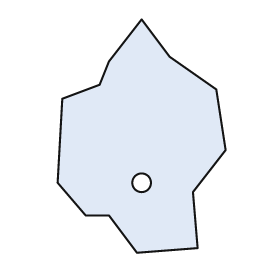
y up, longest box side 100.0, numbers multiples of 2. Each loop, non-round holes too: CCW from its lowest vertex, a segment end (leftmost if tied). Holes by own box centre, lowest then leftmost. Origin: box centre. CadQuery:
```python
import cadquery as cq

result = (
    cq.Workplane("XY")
    .moveTo(-2.0, -50.0)
    .lineTo(24.0, -48.0)
    .lineTo(22.0, -24.0)
    .lineTo(36.0, -6.0)
    .lineTo(32.0, 20.0)
    .lineTo(12.0, 34.0)
    .lineTo(0.0, 50.0)
    .lineTo(-14.0, 32.0)
    .lineTo(-18.0, 22.0)
    .lineTo(-34.0, 16.0)
    .lineTo(-36.0, -20.0)
    .lineTo(-24.0, -34.0)
    .lineTo(-14.0, -34.0)
    .close()
    .moveTo(0.0, -20.0)
    .circle(4.0)
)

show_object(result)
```